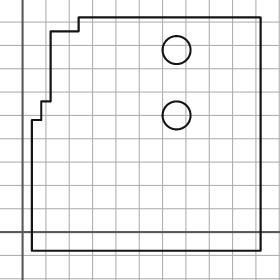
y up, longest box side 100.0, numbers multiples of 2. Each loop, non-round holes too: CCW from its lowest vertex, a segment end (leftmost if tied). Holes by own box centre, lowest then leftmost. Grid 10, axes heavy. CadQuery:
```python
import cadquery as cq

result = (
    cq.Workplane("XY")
    .moveTo(4.0, -8.0)
    .lineTo(102.0, -8.0)
    .lineTo(102.0, 92.0)
    .lineTo(24.0, 92.0)
    .lineTo(24.0, 86.0)
    .lineTo(12.0, 86.0)
    .lineTo(12.0, 56.0)
    .lineTo(8.0, 56.0)
    .lineTo(8.0, 48.0)
    .lineTo(4.0, 48.0)
    .close()
    .moveTo(66.0, 50.0)
    .circle(6.0)
    .moveTo(66.0, 78.0)
    .circle(6.0)
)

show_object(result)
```